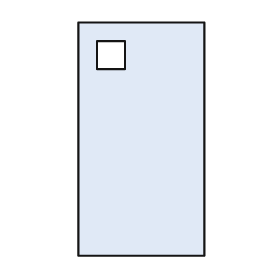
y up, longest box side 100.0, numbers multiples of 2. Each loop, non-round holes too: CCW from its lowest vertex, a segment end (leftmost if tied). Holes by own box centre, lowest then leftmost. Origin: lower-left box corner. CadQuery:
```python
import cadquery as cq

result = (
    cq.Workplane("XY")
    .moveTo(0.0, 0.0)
    .lineTo(54.0, 0.0)
    .lineTo(54.0, 100.0)
    .lineTo(0.0, 100.0)
    .close()
    .moveTo(8.0, 80.0)
    .lineTo(20.0, 80.0)
    .lineTo(20.0, 92.0)
    .lineTo(8.0, 92.0)
    .close()
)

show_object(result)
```